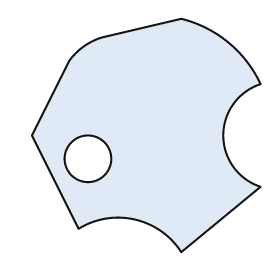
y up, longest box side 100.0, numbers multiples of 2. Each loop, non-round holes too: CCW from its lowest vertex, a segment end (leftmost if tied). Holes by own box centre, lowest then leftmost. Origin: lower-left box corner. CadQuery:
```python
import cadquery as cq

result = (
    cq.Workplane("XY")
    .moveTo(64.0, 0.0)
    .lineTo(98.0, 28.0)
    .threePointArc((82.0, 50.0), (98.0, 72.0))
    .threePointArc((84.0, 90.0), (64.0, 100.0))
    .lineTo(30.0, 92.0)
    .threePointArc((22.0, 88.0), (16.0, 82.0))
    .lineTo(0.0, 50.0)
    .lineTo(20.0, 10.0)
    .threePointArc((44.0, 14.0), (64.0, 0.0))
    .close()
    .moveTo(24.0, 40.0)
    .circle(10.0)
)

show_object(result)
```